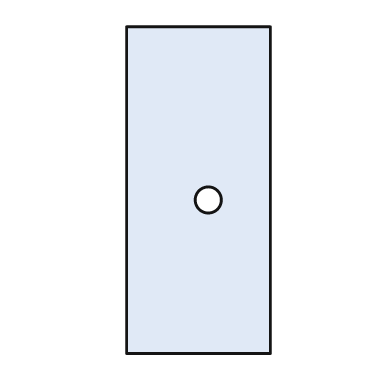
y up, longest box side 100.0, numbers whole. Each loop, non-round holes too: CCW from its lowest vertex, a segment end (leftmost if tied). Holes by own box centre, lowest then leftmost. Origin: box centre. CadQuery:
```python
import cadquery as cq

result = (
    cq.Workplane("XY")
    .moveTo(-22.0, -50.0)
    .lineTo(22.0, -50.0)
    .lineTo(22.0, 50.0)
    .lineTo(-22.0, 50.0)
    .close()
    .moveTo(3.0, -3.0)
    .circle(4.0)
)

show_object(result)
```